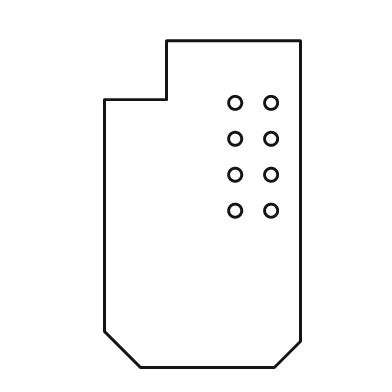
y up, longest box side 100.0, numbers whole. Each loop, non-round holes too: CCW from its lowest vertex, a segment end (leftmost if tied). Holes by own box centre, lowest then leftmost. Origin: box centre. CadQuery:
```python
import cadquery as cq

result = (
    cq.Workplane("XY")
    .moveTo(-19.0, -50.0)
    .lineTo(22.0, -50.0)
    .lineTo(30.0, -42.0)
    .lineTo(30.0, 50.0)
    .lineTo(-11.0, 50.0)
    .lineTo(-11.0, 32.0)
    .lineTo(-30.0, 32.0)
    .lineTo(-30.0, -39.0)
    .close()
    .moveTo(10.0, -2.0)
    .circle(2.0)
    .moveTo(21.0, -2.0)
    .circle(2.0)
    .moveTo(10.0, 9.0)
    .circle(2.0)
    .moveTo(21.0, 9.0)
    .circle(2.0)
    .moveTo(10.0, 20.0)
    .circle(2.0)
    .moveTo(21.0, 20.0)
    .circle(2.0)
    .moveTo(10.0, 31.0)
    .circle(2.0)
    .moveTo(21.0, 31.0)
    .circle(2.0)
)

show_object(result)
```